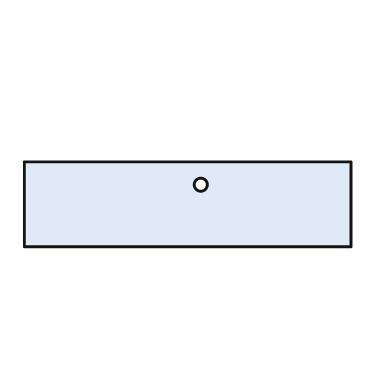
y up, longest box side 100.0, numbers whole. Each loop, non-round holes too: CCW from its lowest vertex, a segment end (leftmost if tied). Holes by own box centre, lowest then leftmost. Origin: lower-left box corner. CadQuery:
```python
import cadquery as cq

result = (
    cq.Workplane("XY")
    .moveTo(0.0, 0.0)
    .lineTo(100.0, 0.0)
    .lineTo(100.0, 26.0)
    .lineTo(0.0, 26.0)
    .close()
    .moveTo(54.0, 19.0)
    .circle(2.0)
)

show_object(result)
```